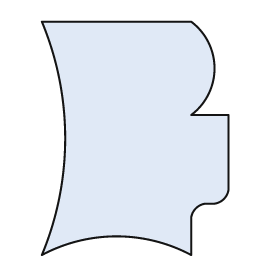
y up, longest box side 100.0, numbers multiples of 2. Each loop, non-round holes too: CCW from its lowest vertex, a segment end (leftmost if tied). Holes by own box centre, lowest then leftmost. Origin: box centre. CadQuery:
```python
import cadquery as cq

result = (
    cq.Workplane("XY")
    .moveTo(-40.0, -50.0)
    .threePointArc((-8.0, -42.0), (24.0, -50.0))
    .lineTo(24.0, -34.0)
    .threePointArc((26.0, -30.0), (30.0, -28.0))
    .lineTo(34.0, -28.0)
    .threePointArc((38.0, -26.0), (40.0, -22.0))
    .lineTo(40.0, 10.0)
    .lineTo(24.0, 10.0)
    .threePointArc((34.0, 30.0), (24.0, 50.0))
    .lineTo(-40.0, 50.0)
    .threePointArc((-30.0, 0.0), (-40.0, -50.0))
    .close()
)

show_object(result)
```